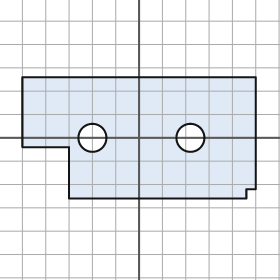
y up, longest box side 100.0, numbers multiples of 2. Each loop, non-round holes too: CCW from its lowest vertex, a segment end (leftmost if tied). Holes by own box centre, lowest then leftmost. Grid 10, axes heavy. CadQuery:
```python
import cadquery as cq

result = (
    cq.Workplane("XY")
    .moveTo(-30.0, -26.0)
    .lineTo(46.0, -26.0)
    .lineTo(46.0, -22.0)
    .lineTo(50.0, -22.0)
    .lineTo(50.0, 26.0)
    .lineTo(-50.0, 26.0)
    .lineTo(-50.0, -4.0)
    .lineTo(-30.0, -4.0)
    .close()
    .moveTo(-20.0, 0.0)
    .circle(6.0)
    .moveTo(22.0, 0.0)
    .circle(6.0)
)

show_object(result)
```